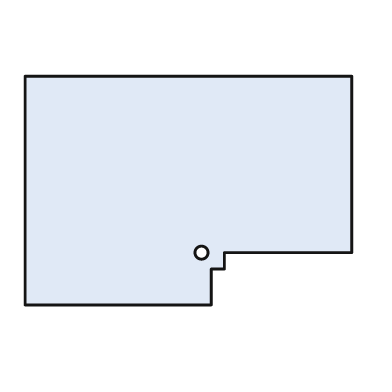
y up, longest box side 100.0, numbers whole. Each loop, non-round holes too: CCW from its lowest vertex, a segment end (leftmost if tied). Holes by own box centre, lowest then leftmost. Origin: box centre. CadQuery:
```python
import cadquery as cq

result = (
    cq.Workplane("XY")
    .moveTo(-50.0, -35.0)
    .lineTo(7.0, -35.0)
    .lineTo(7.0, -24.0)
    .lineTo(11.0, -24.0)
    .lineTo(11.0, -19.0)
    .lineTo(50.0, -19.0)
    .lineTo(50.0, 35.0)
    .lineTo(-50.0, 35.0)
    .close()
    .moveTo(4.0, -19.0)
    .circle(2.0)
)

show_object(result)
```